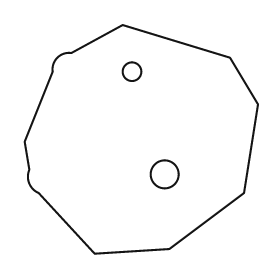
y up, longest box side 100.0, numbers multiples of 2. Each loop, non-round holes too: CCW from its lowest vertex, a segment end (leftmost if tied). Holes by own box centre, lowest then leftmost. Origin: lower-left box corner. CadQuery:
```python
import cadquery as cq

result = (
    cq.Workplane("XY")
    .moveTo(30.0, 0.0)
    .lineTo(62.0, 2.0)
    .lineTo(94.0, 26.0)
    .lineTo(100.0, 64.0)
    .lineTo(88.0, 84.0)
    .lineTo(42.0, 98.0)
    .lineTo(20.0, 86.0)
    .threePointArc((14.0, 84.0), (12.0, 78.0))
    .lineTo(0.0, 48.0)
    .lineTo(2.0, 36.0)
    .threePointArc((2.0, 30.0), (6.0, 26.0))
    .close()
    .moveTo(60.0, 34.0)
    .circle(6.0)
    .moveTo(46.0, 78.0)
    .circle(4.0)
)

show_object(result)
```